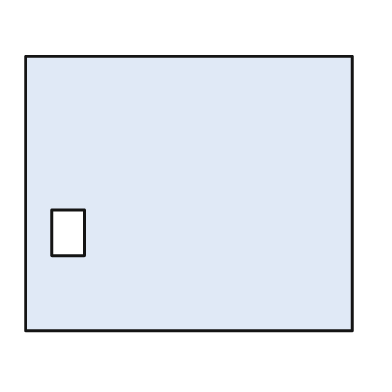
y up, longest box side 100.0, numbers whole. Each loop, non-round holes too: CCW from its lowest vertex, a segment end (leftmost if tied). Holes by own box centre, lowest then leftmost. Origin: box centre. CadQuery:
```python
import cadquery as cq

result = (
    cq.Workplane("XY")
    .moveTo(-50.0, -42.0)
    .lineTo(50.0, -42.0)
    .lineTo(50.0, 42.0)
    .lineTo(-50.0, 42.0)
    .close()
    .moveTo(-42.0, -19.0)
    .lineTo(-32.0, -19.0)
    .lineTo(-32.0, -5.0)
    .lineTo(-42.0, -5.0)
    .close()
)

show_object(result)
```